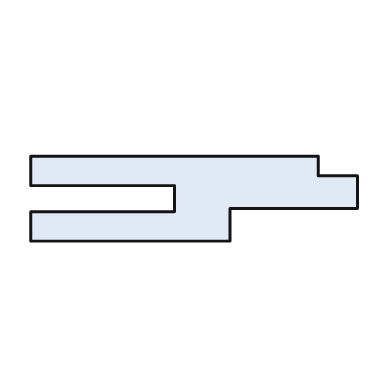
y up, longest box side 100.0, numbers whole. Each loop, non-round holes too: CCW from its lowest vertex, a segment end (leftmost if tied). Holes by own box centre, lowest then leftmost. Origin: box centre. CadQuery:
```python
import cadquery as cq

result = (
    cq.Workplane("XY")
    .moveTo(-50.0, -13.0)
    .lineTo(11.0, -13.0)
    .lineTo(11.0, -3.0)
    .lineTo(50.0, -3.0)
    .lineTo(50.0, 7.0)
    .lineTo(38.0, 7.0)
    .lineTo(38.0, 13.0)
    .lineTo(-50.0, 13.0)
    .lineTo(-50.0, 4.0)
    .lineTo(-6.0, 4.0)
    .lineTo(-6.0, -4.0)
    .lineTo(-50.0, -4.0)
    .close()
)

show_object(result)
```